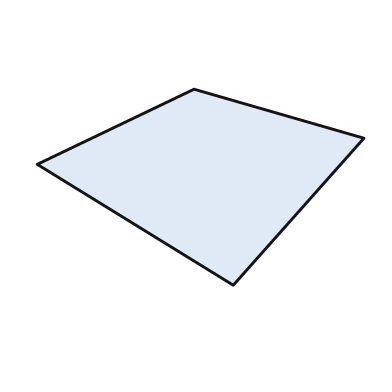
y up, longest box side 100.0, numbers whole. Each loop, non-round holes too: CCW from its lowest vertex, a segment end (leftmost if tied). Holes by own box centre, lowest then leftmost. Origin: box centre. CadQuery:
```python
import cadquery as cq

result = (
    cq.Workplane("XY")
    .moveTo(10.0, -30.0)
    .lineTo(50.0, 15.0)
    .lineTo(-2.0, 30.0)
    .lineTo(-50.0, 7.0)
    .close()
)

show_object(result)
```